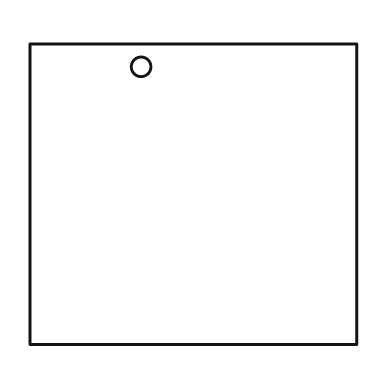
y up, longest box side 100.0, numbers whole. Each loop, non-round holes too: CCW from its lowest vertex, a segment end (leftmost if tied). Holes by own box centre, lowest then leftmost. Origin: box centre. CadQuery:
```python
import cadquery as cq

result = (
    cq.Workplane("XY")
    .moveTo(-50.0, -46.0)
    .lineTo(50.0, -46.0)
    .lineTo(50.0, 46.0)
    .lineTo(-50.0, 46.0)
    .close()
    .moveTo(-16.0, 39.0)
    .circle(3.0)
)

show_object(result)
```